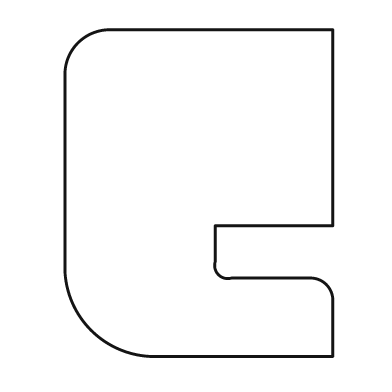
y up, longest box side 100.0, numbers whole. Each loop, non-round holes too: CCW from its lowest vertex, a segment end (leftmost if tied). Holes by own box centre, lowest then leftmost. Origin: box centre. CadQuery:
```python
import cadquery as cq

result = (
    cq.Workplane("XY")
    .moveTo(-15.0, -50.0)
    .lineTo(41.0, -50.0)
    .lineTo(41.0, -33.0)
    .threePointArc((39.0, -28.0), (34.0, -26.0))
    .lineTo(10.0, -26.0)
    .threePointArc((6.0, -25.0), (5.0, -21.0))
    .lineTo(5.0, -10.0)
    .lineTo(41.0, -10.0)
    .lineTo(41.0, 50.0)
    .lineTo(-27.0, 50.0)
    .threePointArc((-37.0, 46.0), (-41.0, 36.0))
    .lineTo(-41.0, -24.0)
    .threePointArc((-33.0, -42.0), (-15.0, -50.0))
    .close()
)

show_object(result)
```